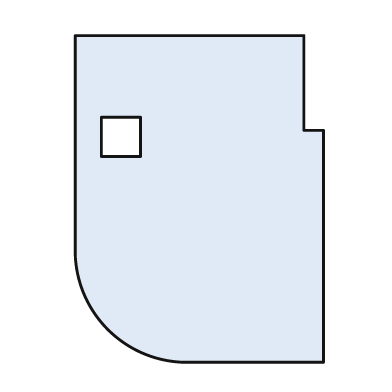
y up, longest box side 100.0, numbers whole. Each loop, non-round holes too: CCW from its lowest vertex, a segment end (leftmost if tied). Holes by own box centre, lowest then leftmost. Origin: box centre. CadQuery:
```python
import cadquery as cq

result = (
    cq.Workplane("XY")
    .moveTo(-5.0, -50.0)
    .lineTo(38.0, -50.0)
    .lineTo(38.0, 21.0)
    .lineTo(32.0, 21.0)
    .lineTo(32.0, 50.0)
    .lineTo(-38.0, 50.0)
    .lineTo(-38.0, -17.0)
    .threePointArc((-28.0, -40.0), (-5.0, -50.0))
    .close()
    .moveTo(-30.0, 13.0)
    .lineTo(-18.0, 13.0)
    .lineTo(-18.0, 25.0)
    .lineTo(-30.0, 25.0)
    .close()
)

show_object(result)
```